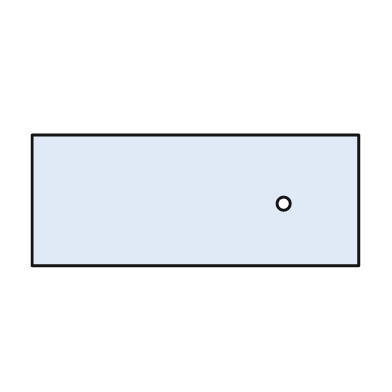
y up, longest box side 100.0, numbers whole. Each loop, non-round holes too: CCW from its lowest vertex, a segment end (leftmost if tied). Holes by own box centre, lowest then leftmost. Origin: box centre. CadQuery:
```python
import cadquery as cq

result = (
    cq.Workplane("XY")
    .moveTo(-50.0, -20.0)
    .lineTo(50.0, -20.0)
    .lineTo(50.0, 20.0)
    .lineTo(-50.0, 20.0)
    .close()
    .moveTo(27.0, -1.0)
    .circle(2.0)
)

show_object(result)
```